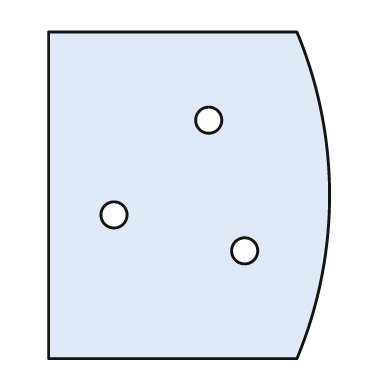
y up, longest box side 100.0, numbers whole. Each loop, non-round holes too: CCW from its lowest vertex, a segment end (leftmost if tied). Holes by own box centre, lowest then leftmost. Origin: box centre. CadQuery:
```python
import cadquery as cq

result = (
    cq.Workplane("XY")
    .moveTo(-43.0, -50.0)
    .lineTo(33.0, -50.0)
    .threePointArc((43.0, 0.0), (33.0, 50.0))
    .lineTo(-43.0, 50.0)
    .close()
    .moveTo(17.0, -17.0)
    .circle(4.0)
    .moveTo(-23.0, -6.0)
    .circle(4.0)
    .moveTo(6.0, 23.0)
    .circle(4.0)
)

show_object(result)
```